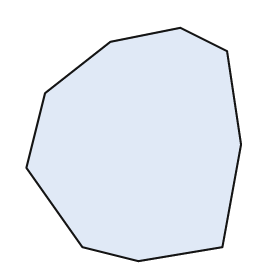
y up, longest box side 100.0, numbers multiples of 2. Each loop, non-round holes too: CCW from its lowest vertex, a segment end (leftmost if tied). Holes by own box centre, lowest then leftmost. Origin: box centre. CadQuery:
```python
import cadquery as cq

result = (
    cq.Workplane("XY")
    .moveTo(2.0, -50.0)
    .lineTo(38.0, -44.0)
    .lineTo(46.0, 0.0)
    .lineTo(40.0, 40.0)
    .lineTo(20.0, 50.0)
    .lineTo(-10.0, 44.0)
    .lineTo(-38.0, 22.0)
    .lineTo(-46.0, -10.0)
    .lineTo(-22.0, -44.0)
    .close()
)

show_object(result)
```